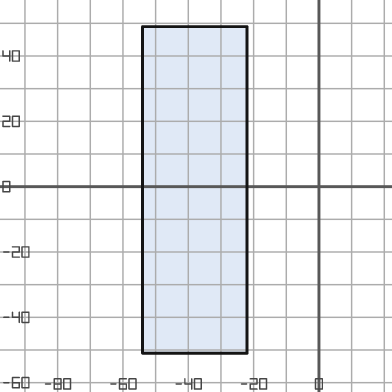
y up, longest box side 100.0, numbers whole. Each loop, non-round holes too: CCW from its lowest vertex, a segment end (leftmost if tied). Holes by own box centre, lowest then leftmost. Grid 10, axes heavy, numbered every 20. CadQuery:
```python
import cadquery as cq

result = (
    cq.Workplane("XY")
    .moveTo(-54.0, -51.0)
    .lineTo(-22.0, -51.0)
    .lineTo(-22.0, 49.0)
    .lineTo(-54.0, 49.0)
    .close()
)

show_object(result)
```